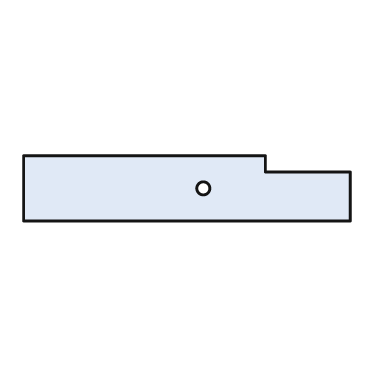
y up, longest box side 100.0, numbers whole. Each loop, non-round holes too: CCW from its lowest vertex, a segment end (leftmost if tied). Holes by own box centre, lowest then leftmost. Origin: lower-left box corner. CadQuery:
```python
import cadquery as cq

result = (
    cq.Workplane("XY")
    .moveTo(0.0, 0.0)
    .lineTo(100.0, 0.0)
    .lineTo(100.0, 15.0)
    .lineTo(74.0, 15.0)
    .lineTo(74.0, 20.0)
    .lineTo(0.0, 20.0)
    .close()
    .moveTo(55.0, 10.0)
    .circle(2.0)
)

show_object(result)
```